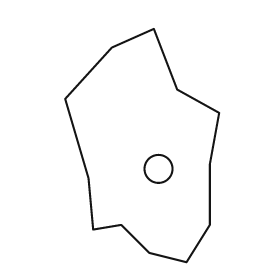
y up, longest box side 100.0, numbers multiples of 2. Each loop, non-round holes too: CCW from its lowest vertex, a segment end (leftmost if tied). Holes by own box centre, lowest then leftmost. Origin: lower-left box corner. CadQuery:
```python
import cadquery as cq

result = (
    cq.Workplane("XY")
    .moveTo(52.0, 0.0)
    .lineTo(62.0, 16.0)
    .lineTo(62.0, 42.0)
    .lineTo(66.0, 64.0)
    .lineTo(48.0, 74.0)
    .lineTo(38.0, 100.0)
    .lineTo(20.0, 92.0)
    .lineTo(0.0, 70.0)
    .lineTo(10.0, 36.0)
    .lineTo(12.0, 14.0)
    .lineTo(24.0, 16.0)
    .lineTo(36.0, 4.0)
    .close()
    .moveTo(40.0, 40.0)
    .circle(6.0)
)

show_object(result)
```